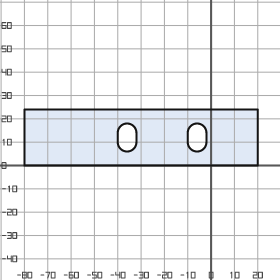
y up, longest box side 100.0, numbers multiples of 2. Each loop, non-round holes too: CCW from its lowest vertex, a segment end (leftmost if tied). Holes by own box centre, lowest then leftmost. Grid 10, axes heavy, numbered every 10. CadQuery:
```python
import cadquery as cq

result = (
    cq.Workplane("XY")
    .moveTo(-80.0, 0.0)
    .lineTo(20.0, 0.0)
    .lineTo(20.0, 24.0)
    .lineTo(-80.0, 24.0)
    .close()
    .moveTo(-40.0, 10.0)
    .threePointArc((-36.0, 6.0), (-32.0, 10.0))
    .lineTo(-32.0, 14.0)
    .threePointArc((-36.0, 18.0), (-40.0, 14.0))
    .close()
    .moveTo(-10.0, 10.0)
    .threePointArc((-6.0, 6.0), (-2.0, 10.0))
    .lineTo(-2.0, 14.0)
    .threePointArc((-6.0, 18.0), (-10.0, 14.0))
    .close()
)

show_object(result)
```